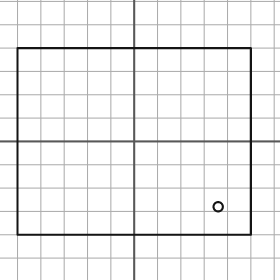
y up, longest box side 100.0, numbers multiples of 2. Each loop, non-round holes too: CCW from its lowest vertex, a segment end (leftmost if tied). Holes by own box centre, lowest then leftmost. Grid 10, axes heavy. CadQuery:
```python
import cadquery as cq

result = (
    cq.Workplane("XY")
    .moveTo(-50.0, -40.0)
    .lineTo(50.0, -40.0)
    .lineTo(50.0, 40.0)
    .lineTo(-50.0, 40.0)
    .close()
    .moveTo(36.0, -28.0)
    .circle(2.0)
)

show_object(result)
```